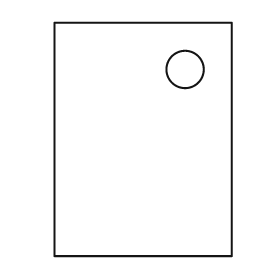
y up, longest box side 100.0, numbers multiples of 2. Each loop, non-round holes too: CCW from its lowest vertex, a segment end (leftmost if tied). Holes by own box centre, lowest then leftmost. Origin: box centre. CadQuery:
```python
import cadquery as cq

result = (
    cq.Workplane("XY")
    .moveTo(-38.0, -50.0)
    .lineTo(38.0, -50.0)
    .lineTo(38.0, 50.0)
    .lineTo(-38.0, 50.0)
    .close()
    .moveTo(18.0, 30.0)
    .circle(8.0)
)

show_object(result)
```